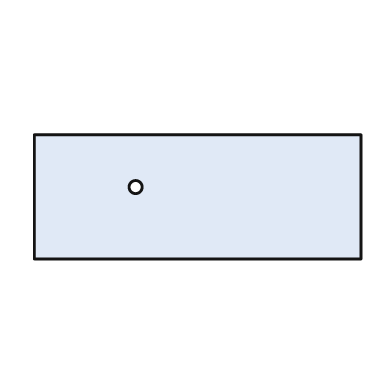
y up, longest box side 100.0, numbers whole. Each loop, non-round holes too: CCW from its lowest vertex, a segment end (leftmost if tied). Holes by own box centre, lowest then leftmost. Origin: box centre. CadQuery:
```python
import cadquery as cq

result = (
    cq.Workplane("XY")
    .moveTo(-50.0, -19.0)
    .lineTo(50.0, -19.0)
    .lineTo(50.0, 19.0)
    .lineTo(-50.0, 19.0)
    .close()
    .moveTo(-19.0, 3.0)
    .circle(2.0)
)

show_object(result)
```